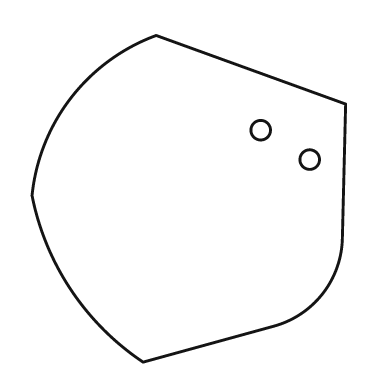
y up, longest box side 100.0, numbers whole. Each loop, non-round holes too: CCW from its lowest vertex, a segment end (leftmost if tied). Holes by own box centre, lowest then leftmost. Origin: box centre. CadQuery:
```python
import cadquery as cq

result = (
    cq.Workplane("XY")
    .moveTo(-14.0, -50.0)
    .lineTo(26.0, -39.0)
    .threePointArc((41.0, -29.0), (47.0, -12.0))
    .lineTo(48.0, 29.0)
    .lineTo(-10.0, 50.0)
    .threePointArc((-36.0, 31.0), (-48.0, 1.0))
    .threePointArc((-36.0, -28.0), (-14.0, -50.0))
    .close()
    .moveTo(37.0, 12.0)
    .circle(3.0)
    .moveTo(22.0, 21.0)
    .circle(3.0)
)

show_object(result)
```